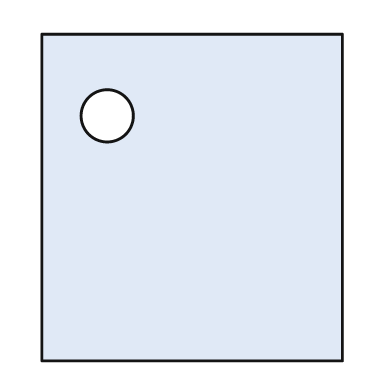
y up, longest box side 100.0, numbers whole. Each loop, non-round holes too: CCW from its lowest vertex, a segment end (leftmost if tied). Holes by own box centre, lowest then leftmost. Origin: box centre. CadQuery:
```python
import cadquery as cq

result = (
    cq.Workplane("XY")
    .moveTo(-46.0, -50.0)
    .lineTo(46.0, -50.0)
    .lineTo(46.0, 50.0)
    .lineTo(-46.0, 50.0)
    .close()
    .moveTo(-26.0, 25.0)
    .circle(8.0)
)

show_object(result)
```